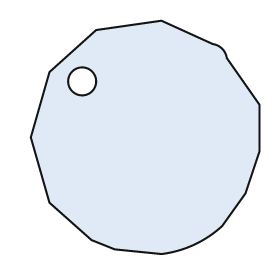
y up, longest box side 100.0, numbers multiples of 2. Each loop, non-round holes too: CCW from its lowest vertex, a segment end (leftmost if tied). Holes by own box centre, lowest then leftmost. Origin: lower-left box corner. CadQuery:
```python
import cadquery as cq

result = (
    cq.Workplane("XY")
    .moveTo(56.0, 0.0)
    .threePointArc((70.0, 4.0), (82.0, 12.0))
    .lineTo(92.0, 26.0)
    .lineTo(98.0, 44.0)
    .lineTo(98.0, 64.0)
    .lineTo(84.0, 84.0)
    .threePointArc((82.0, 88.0), (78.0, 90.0))
    .lineTo(56.0, 100.0)
    .lineTo(28.0, 96.0)
    .lineTo(8.0, 78.0)
    .lineTo(0.0, 50.0)
    .lineTo(8.0, 22.0)
    .lineTo(26.0, 6.0)
    .lineTo(36.0, 2.0)
    .close()
    .moveTo(22.0, 74.0)
    .circle(6.0)
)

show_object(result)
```